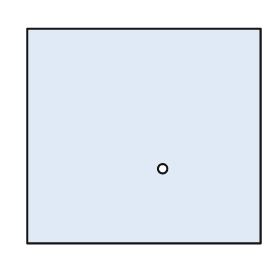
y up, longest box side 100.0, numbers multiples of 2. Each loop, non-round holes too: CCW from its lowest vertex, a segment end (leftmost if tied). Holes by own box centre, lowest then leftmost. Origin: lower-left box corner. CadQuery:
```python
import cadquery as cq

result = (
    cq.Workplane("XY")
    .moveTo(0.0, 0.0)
    .lineTo(100.0, 0.0)
    .lineTo(100.0, 92.0)
    .lineTo(0.0, 92.0)
    .close()
    .moveTo(58.0, 32.0)
    .circle(2.0)
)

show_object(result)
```